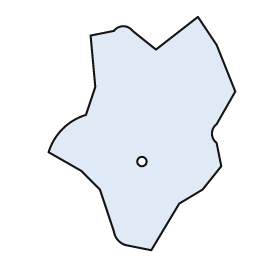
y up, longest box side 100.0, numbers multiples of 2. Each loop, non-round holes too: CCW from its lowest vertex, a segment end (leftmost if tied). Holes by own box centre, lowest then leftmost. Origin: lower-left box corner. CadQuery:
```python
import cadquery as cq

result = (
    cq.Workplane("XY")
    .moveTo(44.0, 0.0)
    .lineTo(56.0, 20.0)
    .lineTo(66.0, 26.0)
    .lineTo(74.0, 36.0)
    .lineTo(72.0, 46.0)
    .threePointArc((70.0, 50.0), (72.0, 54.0))
    .lineTo(80.0, 68.0)
    .lineTo(72.0, 88.0)
    .lineTo(64.0, 100.0)
    .lineTo(46.0, 86.0)
    .lineTo(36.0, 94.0)
    .threePointArc((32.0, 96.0), (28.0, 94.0))
    .lineTo(18.0, 92.0)
    .lineTo(20.0, 70.0)
    .lineTo(16.0, 58.0)
    .threePointArc((6.0, 52.0), (0.0, 42.0))
    .lineTo(14.0, 34.0)
    .lineTo(22.0, 26.0)
    .lineTo(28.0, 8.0)
    .threePointArc((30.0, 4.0), (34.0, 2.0))
    .close()
    .moveTo(40.0, 38.0)
    .circle(2.0)
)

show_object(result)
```